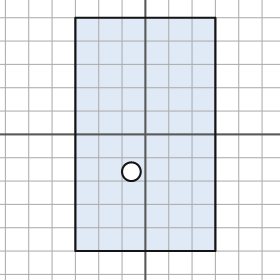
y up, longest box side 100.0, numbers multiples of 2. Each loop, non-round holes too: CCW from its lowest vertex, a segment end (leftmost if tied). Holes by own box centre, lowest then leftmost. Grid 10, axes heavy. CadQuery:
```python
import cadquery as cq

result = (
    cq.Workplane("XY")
    .moveTo(-30.0, -50.0)
    .lineTo(30.0, -50.0)
    .lineTo(30.0, 50.0)
    .lineTo(-30.0, 50.0)
    .close()
    .moveTo(-6.0, -16.0)
    .circle(4.0)
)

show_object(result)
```